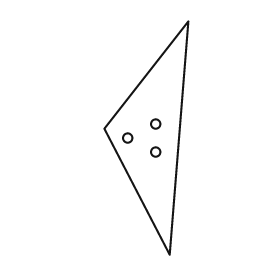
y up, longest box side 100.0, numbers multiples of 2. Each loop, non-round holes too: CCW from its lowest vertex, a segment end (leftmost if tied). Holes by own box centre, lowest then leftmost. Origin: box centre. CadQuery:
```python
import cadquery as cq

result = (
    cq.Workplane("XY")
    .moveTo(10.0, -50.0)
    .lineTo(18.0, 50.0)
    .lineTo(-18.0, 4.0)
    .close()
    .moveTo(4.0, -6.0)
    .circle(2.0)
    .moveTo(-8.0, 0.0)
    .circle(2.0)
    .moveTo(4.0, 6.0)
    .circle(2.0)
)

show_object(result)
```